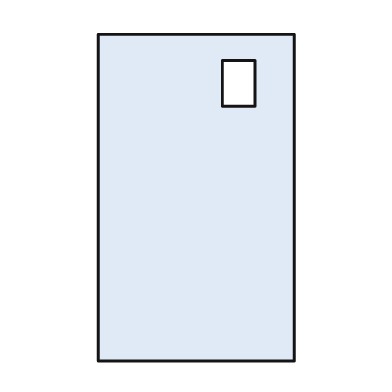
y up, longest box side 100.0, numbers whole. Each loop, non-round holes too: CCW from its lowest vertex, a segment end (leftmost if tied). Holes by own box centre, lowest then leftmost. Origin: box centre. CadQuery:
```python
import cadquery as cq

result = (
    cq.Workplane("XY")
    .moveTo(-30.0, -50.0)
    .lineTo(30.0, -50.0)
    .lineTo(30.0, 50.0)
    .lineTo(-30.0, 50.0)
    .close()
    .moveTo(8.0, 28.0)
    .lineTo(18.0, 28.0)
    .lineTo(18.0, 42.0)
    .lineTo(8.0, 42.0)
    .close()
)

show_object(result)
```